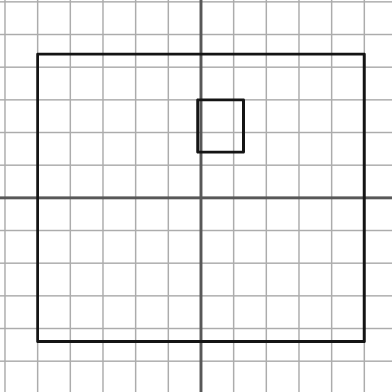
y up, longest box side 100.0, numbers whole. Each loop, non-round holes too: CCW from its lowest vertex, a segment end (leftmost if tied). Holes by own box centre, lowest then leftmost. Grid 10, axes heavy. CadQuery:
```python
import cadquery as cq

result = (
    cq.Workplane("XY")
    .moveTo(-50.0, -44.0)
    .lineTo(50.0, -44.0)
    .lineTo(50.0, 44.0)
    .lineTo(-50.0, 44.0)
    .close()
    .moveTo(-1.0, 14.0)
    .lineTo(13.0, 14.0)
    .lineTo(13.0, 30.0)
    .lineTo(-1.0, 30.0)
    .close()
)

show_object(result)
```